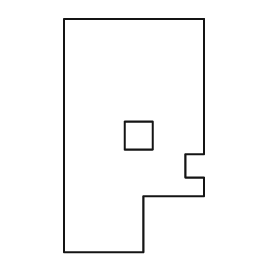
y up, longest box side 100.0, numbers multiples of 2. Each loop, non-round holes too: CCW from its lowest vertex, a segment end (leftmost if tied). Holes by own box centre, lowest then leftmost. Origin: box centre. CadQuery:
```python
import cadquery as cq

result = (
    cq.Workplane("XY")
    .moveTo(-30.0, -50.0)
    .lineTo(4.0, -50.0)
    .lineTo(4.0, -26.0)
    .lineTo(30.0, -26.0)
    .lineTo(30.0, -18.0)
    .lineTo(22.0, -18.0)
    .lineTo(22.0, -8.0)
    .lineTo(30.0, -8.0)
    .lineTo(30.0, 50.0)
    .lineTo(-30.0, 50.0)
    .close()
    .moveTo(-4.0, -6.0)
    .lineTo(8.0, -6.0)
    .lineTo(8.0, 6.0)
    .lineTo(-4.0, 6.0)
    .close()
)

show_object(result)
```